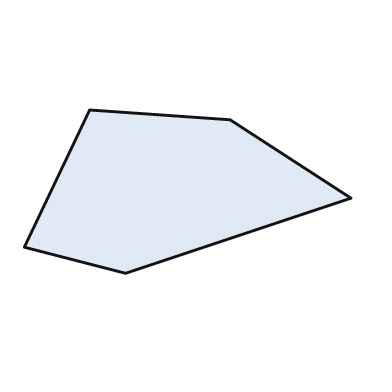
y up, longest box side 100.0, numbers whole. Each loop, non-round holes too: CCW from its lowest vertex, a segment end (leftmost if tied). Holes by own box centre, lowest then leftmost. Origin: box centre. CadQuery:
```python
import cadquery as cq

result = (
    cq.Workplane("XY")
    .moveTo(-19.0, -25.0)
    .lineTo(50.0, -2.0)
    .lineTo(13.0, 22.0)
    .lineTo(-30.0, 25.0)
    .lineTo(-50.0, -17.0)
    .close()
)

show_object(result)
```